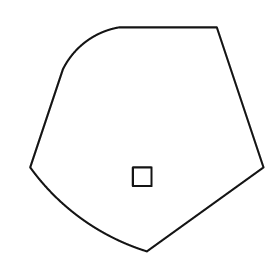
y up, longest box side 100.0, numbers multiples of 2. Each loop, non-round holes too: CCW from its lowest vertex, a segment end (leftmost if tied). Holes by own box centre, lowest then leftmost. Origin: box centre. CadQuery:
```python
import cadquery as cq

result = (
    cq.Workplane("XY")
    .moveTo(0.0, -48.0)
    .lineTo(50.0, -12.0)
    .lineTo(30.0, 48.0)
    .lineTo(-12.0, 48.0)
    .threePointArc((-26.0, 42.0), (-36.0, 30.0))
    .lineTo(-50.0, -12.0)
    .threePointArc((-28.0, -34.0), (0.0, -48.0))
    .close()
    .moveTo(-6.0, -20.0)
    .lineTo(2.0, -20.0)
    .lineTo(2.0, -12.0)
    .lineTo(-6.0, -12.0)
    .close()
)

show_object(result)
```